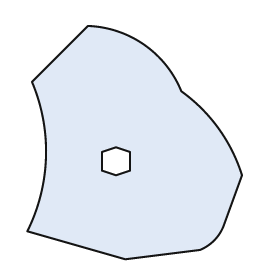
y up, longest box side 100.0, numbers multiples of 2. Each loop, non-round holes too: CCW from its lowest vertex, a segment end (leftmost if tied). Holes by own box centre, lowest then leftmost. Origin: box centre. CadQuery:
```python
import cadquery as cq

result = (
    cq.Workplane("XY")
    .moveTo(-4.0, -50.0)
    .lineTo(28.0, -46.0)
    .threePointArc((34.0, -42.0), (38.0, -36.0))
    .lineTo(46.0, -14.0)
    .threePointArc((36.0, 6.0), (20.0, 22.0))
    .threePointArc((4.0, 42.0), (-20.0, 50.0))
    .lineTo(-44.0, 26.0)
    .threePointArc((-38.0, -6.0), (-46.0, -38.0))
    .close()
    .moveTo(-8.0, -14.0)
    .lineTo(-2.0, -12.0)
    .lineTo(-2.0, -4.0)
    .lineTo(-8.0, -2.0)
    .lineTo(-14.0, -4.0)
    .lineTo(-14.0, -12.0)
    .close()
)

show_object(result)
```